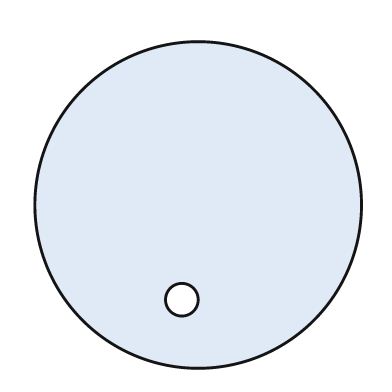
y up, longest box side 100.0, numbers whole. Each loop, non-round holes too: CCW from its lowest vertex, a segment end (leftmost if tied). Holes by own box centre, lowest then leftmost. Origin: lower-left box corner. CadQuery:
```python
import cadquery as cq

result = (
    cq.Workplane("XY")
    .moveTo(50.0, 50.0)
    .circle(50.0)
    .moveTo(45.0, 21.0)
    .circle(5.0)
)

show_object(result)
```